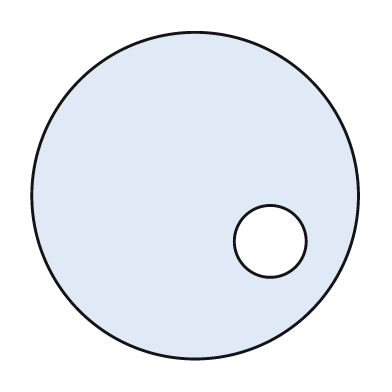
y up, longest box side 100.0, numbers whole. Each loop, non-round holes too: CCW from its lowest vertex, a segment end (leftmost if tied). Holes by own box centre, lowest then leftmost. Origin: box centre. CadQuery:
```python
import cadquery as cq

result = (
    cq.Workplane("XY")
    .moveTo(0.0, 0.0)
    .circle(50.0)
    .moveTo(23.0, -14.0)
    .circle(11.0)
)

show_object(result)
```